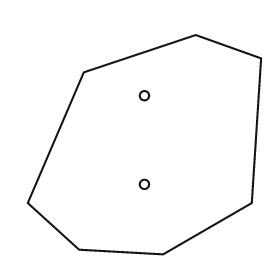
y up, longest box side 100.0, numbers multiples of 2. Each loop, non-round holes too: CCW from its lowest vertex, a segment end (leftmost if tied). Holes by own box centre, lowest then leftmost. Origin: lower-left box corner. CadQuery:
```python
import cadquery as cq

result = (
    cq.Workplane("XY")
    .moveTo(58.0, 0.0)
    .lineTo(96.0, 22.0)
    .lineTo(100.0, 84.0)
    .lineTo(72.0, 94.0)
    .lineTo(24.0, 78.0)
    .lineTo(0.0, 22.0)
    .lineTo(22.0, 2.0)
    .close()
    .moveTo(50.0, 30.0)
    .circle(2.0)
    .moveTo(50.0, 68.0)
    .circle(2.0)
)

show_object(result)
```